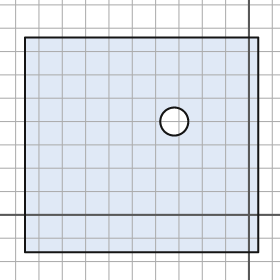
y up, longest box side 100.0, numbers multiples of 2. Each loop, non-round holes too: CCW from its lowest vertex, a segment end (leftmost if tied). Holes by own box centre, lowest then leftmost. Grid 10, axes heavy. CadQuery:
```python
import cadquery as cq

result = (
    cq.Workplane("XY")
    .moveTo(-96.0, -16.0)
    .lineTo(4.0, -16.0)
    .lineTo(4.0, 76.0)
    .lineTo(-96.0, 76.0)
    .close()
    .moveTo(-32.0, 40.0)
    .circle(6.0)
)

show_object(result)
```